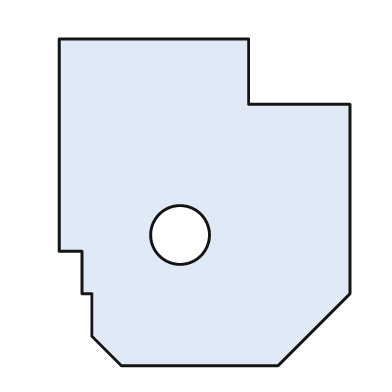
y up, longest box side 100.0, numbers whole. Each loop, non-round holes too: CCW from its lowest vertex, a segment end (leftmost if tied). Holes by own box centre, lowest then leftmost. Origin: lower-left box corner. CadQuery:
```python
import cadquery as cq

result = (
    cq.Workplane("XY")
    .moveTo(19.0, 0.0)
    .lineTo(67.0, 0.0)
    .lineTo(89.0, 22.0)
    .lineTo(89.0, 80.0)
    .lineTo(58.0, 80.0)
    .lineTo(58.0, 100.0)
    .lineTo(0.0, 100.0)
    .lineTo(0.0, 35.0)
    .lineTo(7.0, 35.0)
    .lineTo(7.0, 22.0)
    .lineTo(10.0, 22.0)
    .lineTo(10.0, 9.0)
    .close()
    .moveTo(37.0, 40.0)
    .circle(9.0)
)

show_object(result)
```